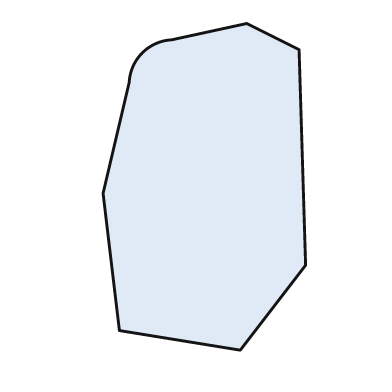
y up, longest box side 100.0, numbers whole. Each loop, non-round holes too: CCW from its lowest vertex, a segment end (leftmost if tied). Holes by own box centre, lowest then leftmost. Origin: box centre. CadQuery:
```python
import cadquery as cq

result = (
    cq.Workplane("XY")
    .moveTo(11.0, -50.0)
    .lineTo(31.0, -24.0)
    .lineTo(29.0, 42.0)
    .lineTo(13.0, 50.0)
    .lineTo(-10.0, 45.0)
    .threePointArc((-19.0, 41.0), (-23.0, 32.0))
    .lineTo(-31.0, -2.0)
    .lineTo(-26.0, -44.0)
    .close()
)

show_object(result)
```